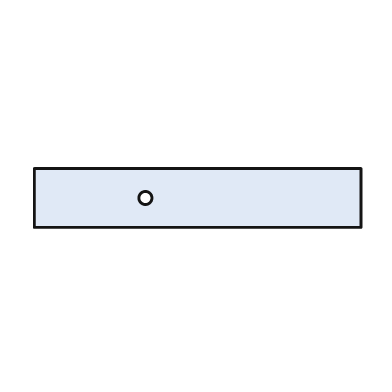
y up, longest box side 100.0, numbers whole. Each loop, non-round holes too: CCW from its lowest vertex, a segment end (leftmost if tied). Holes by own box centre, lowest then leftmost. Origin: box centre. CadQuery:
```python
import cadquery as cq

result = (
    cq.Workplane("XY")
    .moveTo(-50.0, -9.0)
    .lineTo(50.0, -9.0)
    .lineTo(50.0, 9.0)
    .lineTo(-50.0, 9.0)
    .close()
    .moveTo(-16.0, 0.0)
    .circle(2.0)
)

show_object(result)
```